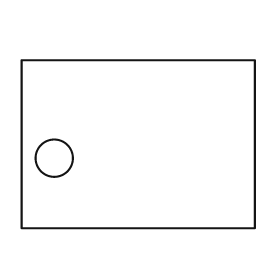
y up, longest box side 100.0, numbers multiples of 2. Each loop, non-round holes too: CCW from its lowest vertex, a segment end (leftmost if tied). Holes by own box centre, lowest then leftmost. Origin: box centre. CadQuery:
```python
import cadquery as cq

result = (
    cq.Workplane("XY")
    .moveTo(-50.0, -36.0)
    .lineTo(50.0, -36.0)
    .lineTo(50.0, 36.0)
    .lineTo(-50.0, 36.0)
    .close()
    .moveTo(-36.0, -6.0)
    .circle(8.0)
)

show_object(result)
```